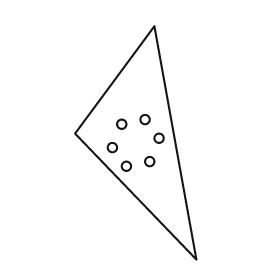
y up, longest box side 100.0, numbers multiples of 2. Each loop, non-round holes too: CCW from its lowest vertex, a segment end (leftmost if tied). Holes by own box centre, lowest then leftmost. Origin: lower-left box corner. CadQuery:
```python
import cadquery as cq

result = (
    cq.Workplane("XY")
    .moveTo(52.0, 0.0)
    .lineTo(34.0, 100.0)
    .lineTo(0.0, 54.0)
    .close()
    .moveTo(22.0, 40.0)
    .circle(2.0)
    .moveTo(32.0, 42.0)
    .circle(2.0)
    .moveTo(16.0, 48.0)
    .circle(2.0)
    .moveTo(36.0, 52.0)
    .circle(2.0)
    .moveTo(20.0, 58.0)
    .circle(2.0)
    .moveTo(30.0, 60.0)
    .circle(2.0)
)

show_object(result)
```